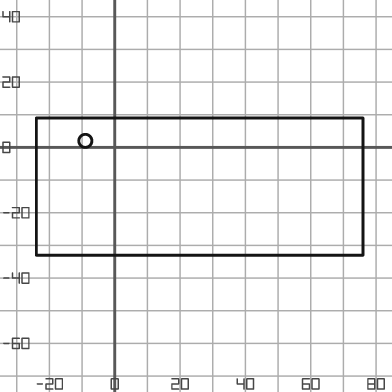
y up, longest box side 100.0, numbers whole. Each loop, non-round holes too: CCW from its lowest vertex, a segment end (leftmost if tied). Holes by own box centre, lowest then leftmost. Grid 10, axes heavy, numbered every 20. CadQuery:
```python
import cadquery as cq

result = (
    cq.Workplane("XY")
    .moveTo(-24.0, -33.0)
    .lineTo(76.0, -33.0)
    .lineTo(76.0, 9.0)
    .lineTo(-24.0, 9.0)
    .close()
    .moveTo(-9.0, 2.0)
    .circle(2.0)
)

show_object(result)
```